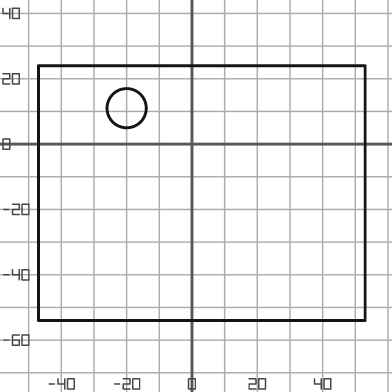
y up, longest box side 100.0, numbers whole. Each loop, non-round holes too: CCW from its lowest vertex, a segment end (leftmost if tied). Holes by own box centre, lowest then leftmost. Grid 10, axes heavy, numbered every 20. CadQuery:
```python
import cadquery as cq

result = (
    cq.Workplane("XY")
    .moveTo(-47.0, -54.0)
    .lineTo(53.0, -54.0)
    .lineTo(53.0, 24.0)
    .lineTo(-47.0, 24.0)
    .close()
    .moveTo(-20.0, 11.0)
    .circle(6.0)
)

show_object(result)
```